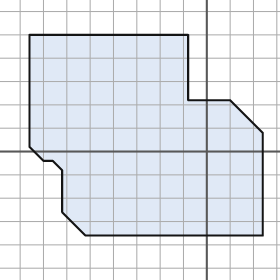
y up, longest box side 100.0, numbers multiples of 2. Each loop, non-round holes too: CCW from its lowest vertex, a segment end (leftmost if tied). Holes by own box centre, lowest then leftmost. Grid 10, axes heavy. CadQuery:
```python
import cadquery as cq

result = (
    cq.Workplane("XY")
    .moveTo(-52.0, -36.0)
    .lineTo(24.0, -36.0)
    .lineTo(24.0, 8.0)
    .lineTo(10.0, 22.0)
    .lineTo(-8.0, 22.0)
    .lineTo(-8.0, 50.0)
    .lineTo(-76.0, 50.0)
    .lineTo(-76.0, 2.0)
    .lineTo(-70.0, -4.0)
    .lineTo(-66.0, -4.0)
    .lineTo(-62.0, -8.0)
    .lineTo(-62.0, -26.0)
    .close()
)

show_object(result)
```